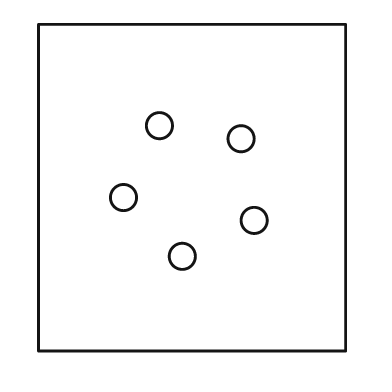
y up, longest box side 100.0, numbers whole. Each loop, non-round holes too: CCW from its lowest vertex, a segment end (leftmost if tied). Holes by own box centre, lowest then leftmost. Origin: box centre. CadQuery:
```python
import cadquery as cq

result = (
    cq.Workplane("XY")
    .moveTo(-47.0, -50.0)
    .lineTo(47.0, -50.0)
    .lineTo(47.0, 50.0)
    .lineTo(-47.0, 50.0)
    .close()
    .moveTo(-3.0, -21.0)
    .circle(4.0)
    .moveTo(19.0, -10.0)
    .circle(4.0)
    .moveTo(-21.0, -3.0)
    .circle(4.0)
    .moveTo(15.0, 15.0)
    .circle(4.0)
    .moveTo(-10.0, 19.0)
    .circle(4.0)
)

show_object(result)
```